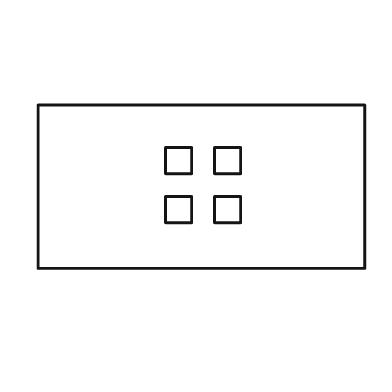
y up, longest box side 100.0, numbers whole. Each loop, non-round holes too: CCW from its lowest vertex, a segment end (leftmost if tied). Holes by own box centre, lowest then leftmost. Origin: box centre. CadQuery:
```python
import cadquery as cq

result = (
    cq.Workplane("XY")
    .moveTo(-50.0, -25.0)
    .lineTo(50.0, -25.0)
    .lineTo(50.0, 25.0)
    .lineTo(-50.0, 25.0)
    .close()
    .moveTo(-11.0, -11.0)
    .lineTo(-3.0, -11.0)
    .lineTo(-3.0, -3.0)
    .lineTo(-11.0, -3.0)
    .close()
    .moveTo(4.0, -11.0)
    .lineTo(12.0, -11.0)
    .lineTo(12.0, -3.0)
    .lineTo(4.0, -3.0)
    .close()
    .moveTo(-11.0, 4.0)
    .lineTo(-3.0, 4.0)
    .lineTo(-3.0, 12.0)
    .lineTo(-11.0, 12.0)
    .close()
    .moveTo(4.0, 4.0)
    .lineTo(12.0, 4.0)
    .lineTo(12.0, 12.0)
    .lineTo(4.0, 12.0)
    .close()
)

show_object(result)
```